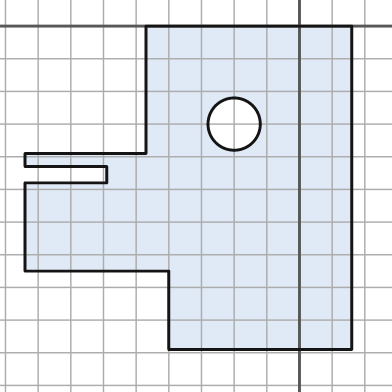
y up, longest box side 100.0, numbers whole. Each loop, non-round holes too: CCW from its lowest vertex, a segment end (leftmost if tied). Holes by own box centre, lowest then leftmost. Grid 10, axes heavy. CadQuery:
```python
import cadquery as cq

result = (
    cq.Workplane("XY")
    .moveTo(-40.0, -99.0)
    .lineTo(16.0, -99.0)
    .lineTo(16.0, 0.0)
    .lineTo(-47.0, 0.0)
    .lineTo(-47.0, -39.0)
    .lineTo(-84.0, -39.0)
    .lineTo(-84.0, -43.0)
    .lineTo(-59.0, -43.0)
    .lineTo(-59.0, -48.0)
    .lineTo(-84.0, -48.0)
    .lineTo(-84.0, -75.0)
    .lineTo(-40.0, -75.0)
    .close()
    .moveTo(-20.0, -30.0)
    .circle(8.0)
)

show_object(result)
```